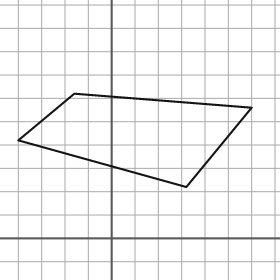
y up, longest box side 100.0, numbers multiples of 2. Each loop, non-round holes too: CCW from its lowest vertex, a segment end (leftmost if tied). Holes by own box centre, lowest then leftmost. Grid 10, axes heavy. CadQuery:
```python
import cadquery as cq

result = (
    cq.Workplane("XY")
    .moveTo(32.0, 22.0)
    .lineTo(60.0, 56.0)
    .lineTo(-16.0, 62.0)
    .lineTo(-40.0, 42.0)
    .close()
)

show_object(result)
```